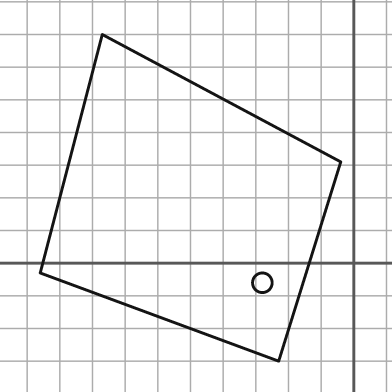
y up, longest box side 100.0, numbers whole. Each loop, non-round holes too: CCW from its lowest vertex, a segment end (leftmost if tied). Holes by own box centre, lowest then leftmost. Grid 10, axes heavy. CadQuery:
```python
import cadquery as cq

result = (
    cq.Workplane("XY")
    .moveTo(-23.0, -30.0)
    .lineTo(-4.0, 31.0)
    .lineTo(-77.0, 70.0)
    .lineTo(-96.0, -3.0)
    .close()
    .moveTo(-28.0, -6.0)
    .circle(3.0)
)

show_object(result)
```